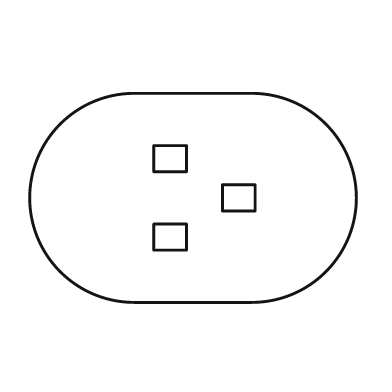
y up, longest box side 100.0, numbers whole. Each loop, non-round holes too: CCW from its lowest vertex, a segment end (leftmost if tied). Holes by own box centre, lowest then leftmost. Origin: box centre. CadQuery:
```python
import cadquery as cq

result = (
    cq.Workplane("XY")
    .moveTo(-18.0, -32.0)
    .lineTo(18.0, -32.0)
    .threePointArc((50.0, 0.0), (18.0, 32.0))
    .lineTo(-18.0, 32.0)
    .threePointArc((-50.0, 0.0), (-18.0, -32.0))
    .close()
    .moveTo(-12.0, -16.0)
    .lineTo(-2.0, -16.0)
    .lineTo(-2.0, -8.0)
    .lineTo(-12.0, -8.0)
    .close()
    .moveTo(9.0, -4.0)
    .lineTo(19.0, -4.0)
    .lineTo(19.0, 4.0)
    .lineTo(9.0, 4.0)
    .close()
    .moveTo(-12.0, 8.0)
    .lineTo(-2.0, 8.0)
    .lineTo(-2.0, 16.0)
    .lineTo(-12.0, 16.0)
    .close()
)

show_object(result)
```